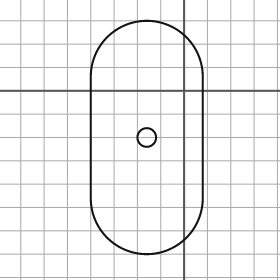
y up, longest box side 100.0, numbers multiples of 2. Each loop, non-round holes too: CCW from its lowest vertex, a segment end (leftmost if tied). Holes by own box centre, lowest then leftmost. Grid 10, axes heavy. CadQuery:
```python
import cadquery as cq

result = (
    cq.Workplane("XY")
    .moveTo(-40.0, -46.0)
    .threePointArc((-16.0, -70.0), (8.0, -46.0))
    .lineTo(8.0, 6.0)
    .threePointArc((-16.0, 30.0), (-40.0, 6.0))
    .close()
    .moveTo(-16.0, -20.0)
    .circle(4.0)
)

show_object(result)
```